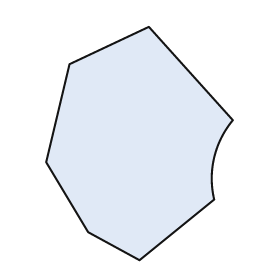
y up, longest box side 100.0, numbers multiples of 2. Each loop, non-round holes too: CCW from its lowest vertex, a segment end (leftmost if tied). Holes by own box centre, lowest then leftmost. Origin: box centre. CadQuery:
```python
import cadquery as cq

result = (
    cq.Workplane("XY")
    .moveTo(0.0, -50.0)
    .lineTo(32.0, -24.0)
    .threePointArc((32.0, -6.0), (40.0, 10.0))
    .lineTo(4.0, 50.0)
    .lineTo(-30.0, 34.0)
    .lineTo(-40.0, -8.0)
    .lineTo(-22.0, -38.0)
    .close()
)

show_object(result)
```